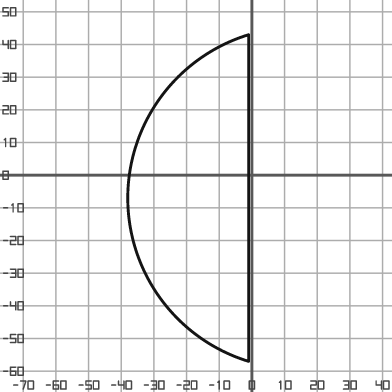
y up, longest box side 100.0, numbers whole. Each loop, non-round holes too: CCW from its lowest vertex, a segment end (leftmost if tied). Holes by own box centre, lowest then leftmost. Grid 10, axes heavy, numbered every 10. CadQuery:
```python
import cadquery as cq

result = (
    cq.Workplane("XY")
    .moveTo(-1.0, -57.0)
    .lineTo(-1.0, 43.0)
    .threePointArc((-38.0, -7.0), (-1.0, -57.0))
    .close()
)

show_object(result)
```